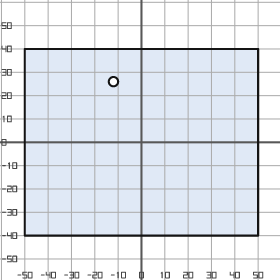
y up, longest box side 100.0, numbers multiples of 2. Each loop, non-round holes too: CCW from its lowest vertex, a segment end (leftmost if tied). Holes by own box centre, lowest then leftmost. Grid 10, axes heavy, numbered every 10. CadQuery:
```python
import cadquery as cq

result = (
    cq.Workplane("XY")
    .moveTo(-50.0, -40.0)
    .lineTo(50.0, -40.0)
    .lineTo(50.0, 40.0)
    .lineTo(-50.0, 40.0)
    .close()
    .moveTo(-12.0, 26.0)
    .circle(2.0)
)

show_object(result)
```